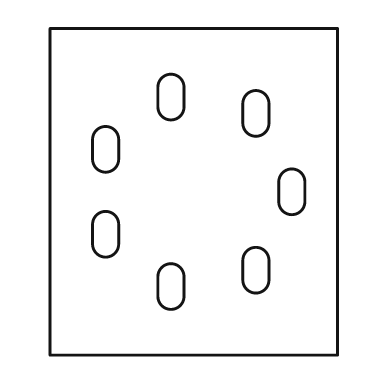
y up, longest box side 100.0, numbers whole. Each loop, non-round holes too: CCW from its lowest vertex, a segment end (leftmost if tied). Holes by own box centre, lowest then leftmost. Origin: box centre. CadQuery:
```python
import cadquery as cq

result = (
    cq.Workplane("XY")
    .moveTo(-44.0, -50.0)
    .lineTo(44.0, -50.0)
    .lineTo(44.0, 50.0)
    .lineTo(-44.0, 50.0)
    .close()
    .moveTo(-11.0, -32.0)
    .threePointArc((-7.0, -36.0), (-3.0, -32.0))
    .lineTo(-3.0, -26.0)
    .threePointArc((-7.0, -22.0), (-11.0, -26.0))
    .close()
    .moveTo(15.0, -27.0)
    .threePointArc((19.0, -31.0), (23.0, -27.0))
    .lineTo(23.0, -21.0)
    .threePointArc((19.0, -17.0), (15.0, -21.0))
    .close()
    .moveTo(-31.0, -16.0)
    .threePointArc((-27.0, -20.0), (-23.0, -16.0))
    .lineTo(-23.0, -10.0)
    .threePointArc((-27.0, -6.0), (-31.0, -10.0))
    .close()
    .moveTo(26.0, -3.0)
    .threePointArc((30.0, -7.0), (34.0, -3.0))
    .lineTo(34.0, 3.0)
    .threePointArc((30.0, 7.0), (26.0, 3.0))
    .close()
    .moveTo(-31.0, 10.0)
    .threePointArc((-27.0, 6.0), (-23.0, 10.0))
    .lineTo(-23.0, 16.0)
    .threePointArc((-27.0, 20.0), (-31.0, 16.0))
    .close()
    .moveTo(15.0, 21.0)
    .threePointArc((19.0, 17.0), (23.0, 21.0))
    .lineTo(23.0, 27.0)
    .threePointArc((19.0, 31.0), (15.0, 27.0))
    .close()
    .moveTo(-11.0, 26.0)
    .threePointArc((-7.0, 22.0), (-3.0, 26.0))
    .lineTo(-3.0, 32.0)
    .threePointArc((-7.0, 36.0), (-11.0, 32.0))
    .close()
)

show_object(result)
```